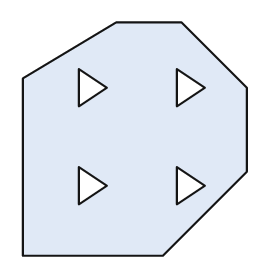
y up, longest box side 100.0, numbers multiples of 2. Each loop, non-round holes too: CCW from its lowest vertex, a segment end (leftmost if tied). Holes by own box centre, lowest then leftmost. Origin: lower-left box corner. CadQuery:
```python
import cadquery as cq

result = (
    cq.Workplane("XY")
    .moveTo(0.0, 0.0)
    .lineTo(60.0, 0.0)
    .lineTo(96.0, 36.0)
    .lineTo(96.0, 72.0)
    .lineTo(68.0, 100.0)
    .lineTo(40.0, 100.0)
    .lineTo(0.0, 76.0)
    .close()
    .moveTo(24.0, 22.0)
    .lineTo(36.0, 30.0)
    .lineTo(24.0, 38.0)
    .close()
    .moveTo(66.0, 22.0)
    .lineTo(78.0, 30.0)
    .lineTo(66.0, 38.0)
    .close()
    .moveTo(24.0, 64.0)
    .lineTo(36.0, 72.0)
    .lineTo(24.0, 80.0)
    .close()
    .moveTo(66.0, 64.0)
    .lineTo(78.0, 72.0)
    .lineTo(66.0, 80.0)
    .close()
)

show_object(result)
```